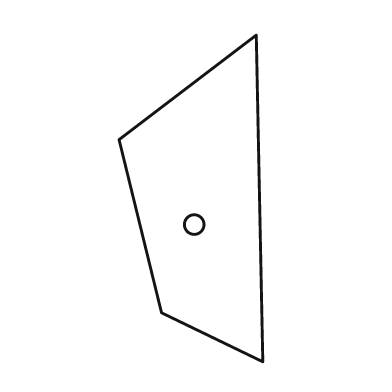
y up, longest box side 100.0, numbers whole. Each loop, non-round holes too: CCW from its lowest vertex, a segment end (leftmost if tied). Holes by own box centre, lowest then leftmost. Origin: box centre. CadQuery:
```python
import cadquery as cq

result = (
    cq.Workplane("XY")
    .moveTo(22.0, -50.0)
    .lineTo(20.0, 50.0)
    .lineTo(-22.0, 18.0)
    .lineTo(-9.0, -35.0)
    .close()
    .moveTo(1.0, -8.0)
    .circle(3.0)
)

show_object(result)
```